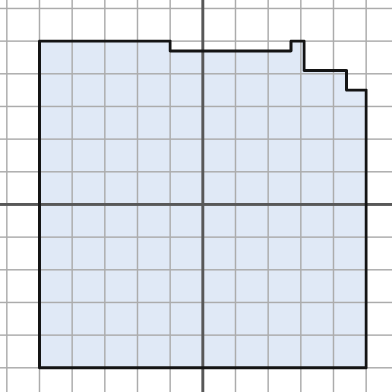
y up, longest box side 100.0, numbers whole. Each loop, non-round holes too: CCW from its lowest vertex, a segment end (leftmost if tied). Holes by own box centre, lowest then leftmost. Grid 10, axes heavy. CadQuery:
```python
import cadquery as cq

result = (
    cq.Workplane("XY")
    .moveTo(-50.0, -50.0)
    .lineTo(50.0, -50.0)
    .lineTo(50.0, 35.0)
    .lineTo(44.0, 35.0)
    .lineTo(44.0, 41.0)
    .lineTo(31.0, 41.0)
    .lineTo(31.0, 50.0)
    .lineTo(27.0, 50.0)
    .lineTo(27.0, 47.0)
    .lineTo(-10.0, 47.0)
    .lineTo(-10.0, 50.0)
    .lineTo(-50.0, 50.0)
    .close()
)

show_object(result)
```